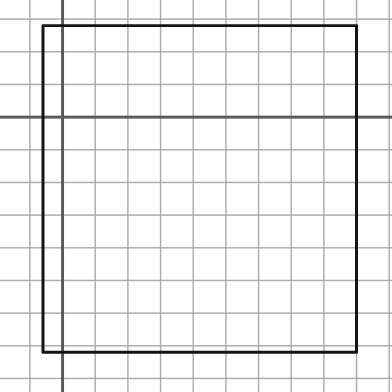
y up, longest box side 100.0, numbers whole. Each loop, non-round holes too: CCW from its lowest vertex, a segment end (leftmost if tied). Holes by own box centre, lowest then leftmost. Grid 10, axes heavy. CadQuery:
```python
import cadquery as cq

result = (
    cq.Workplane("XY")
    .moveTo(-6.0, -72.0)
    .lineTo(90.0, -72.0)
    .lineTo(90.0, 28.0)
    .lineTo(-6.0, 28.0)
    .close()
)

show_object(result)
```